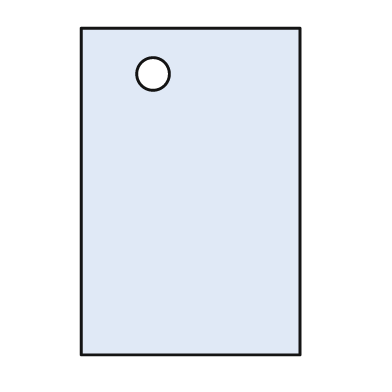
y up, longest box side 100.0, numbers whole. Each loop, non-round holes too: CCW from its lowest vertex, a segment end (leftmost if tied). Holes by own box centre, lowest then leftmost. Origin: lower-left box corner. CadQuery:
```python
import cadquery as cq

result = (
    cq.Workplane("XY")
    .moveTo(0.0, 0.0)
    .lineTo(67.0, 0.0)
    .lineTo(67.0, 100.0)
    .lineTo(0.0, 100.0)
    .close()
    .moveTo(22.0, 86.0)
    .circle(5.0)
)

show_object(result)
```